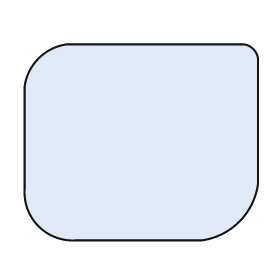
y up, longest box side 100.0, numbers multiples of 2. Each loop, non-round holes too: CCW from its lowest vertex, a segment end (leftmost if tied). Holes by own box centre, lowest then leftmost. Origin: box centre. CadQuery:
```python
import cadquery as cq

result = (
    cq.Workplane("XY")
    .moveTo(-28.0, -42.0)
    .lineTo(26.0, -42.0)
    .threePointArc((42.0, -34.0), (50.0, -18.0))
    .lineTo(50.0, 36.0)
    .threePointArc((48.0, 40.0), (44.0, 42.0))
    .lineTo(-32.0, 42.0)
    .threePointArc((-44.0, 36.0), (-50.0, 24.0))
    .lineTo(-50.0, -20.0)
    .threePointArc((-44.0, -36.0), (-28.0, -42.0))
    .close()
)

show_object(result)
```